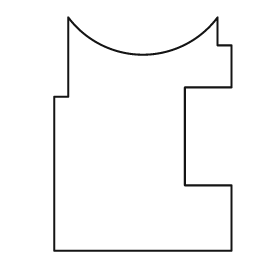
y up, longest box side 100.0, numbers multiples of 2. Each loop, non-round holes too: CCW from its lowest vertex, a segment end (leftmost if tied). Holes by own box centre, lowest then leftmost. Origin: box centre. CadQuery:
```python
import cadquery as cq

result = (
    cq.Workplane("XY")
    .moveTo(-38.0, -50.0)
    .lineTo(38.0, -50.0)
    .lineTo(38.0, -22.0)
    .lineTo(18.0, -22.0)
    .lineTo(18.0, 20.0)
    .lineTo(38.0, 20.0)
    .lineTo(38.0, 38.0)
    .lineTo(32.0, 38.0)
    .lineTo(32.0, 50.0)
    .threePointArc((0.0, 34.0), (-32.0, 50.0))
    .lineTo(-32.0, 16.0)
    .lineTo(-38.0, 16.0)
    .close()
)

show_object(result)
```